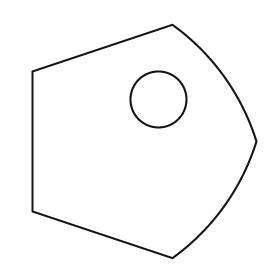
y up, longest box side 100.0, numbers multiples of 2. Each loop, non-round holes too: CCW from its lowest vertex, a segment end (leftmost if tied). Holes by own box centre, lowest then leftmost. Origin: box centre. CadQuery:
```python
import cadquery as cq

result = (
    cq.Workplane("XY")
    .moveTo(12.0, -50.0)
    .threePointArc((34.0, -28.0), (48.0, 0.0))
    .threePointArc((34.0, 28.0), (12.0, 50.0))
    .lineTo(-48.0, 30.0)
    .lineTo(-48.0, -30.0)
    .close()
    .moveTo(6.0, 18.0)
    .circle(12.0)
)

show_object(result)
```